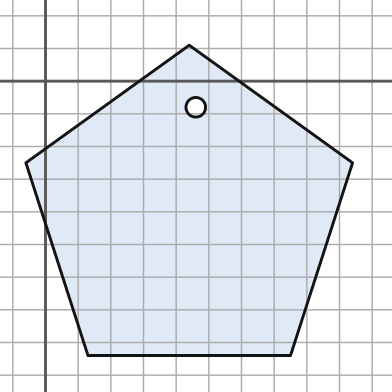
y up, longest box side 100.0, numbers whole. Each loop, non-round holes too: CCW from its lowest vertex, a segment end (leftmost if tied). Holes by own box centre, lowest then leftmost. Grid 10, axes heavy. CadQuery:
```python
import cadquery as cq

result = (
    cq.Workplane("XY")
    .moveTo(13.0, -84.0)
    .lineTo(75.0, -84.0)
    .lineTo(94.0, -25.0)
    .lineTo(44.0, 11.0)
    .lineTo(-6.0, -25.0)
    .close()
    .moveTo(46.0, -8.0)
    .circle(3.0)
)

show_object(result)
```